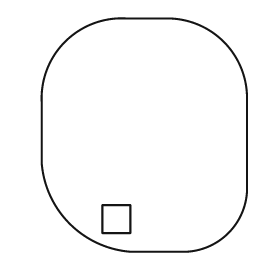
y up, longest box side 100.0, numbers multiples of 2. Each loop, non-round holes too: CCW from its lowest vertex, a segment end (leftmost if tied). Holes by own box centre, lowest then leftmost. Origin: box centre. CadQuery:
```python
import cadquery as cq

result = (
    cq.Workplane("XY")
    .moveTo(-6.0, -50.0)
    .lineTo(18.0, -50.0)
    .threePointArc((36.0, -42.0), (44.0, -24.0))
    .lineTo(44.0, 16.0)
    .threePointArc((34.0, 40.0), (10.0, 50.0))
    .lineTo(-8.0, 50.0)
    .threePointArc((-34.0, 40.0), (-44.0, 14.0))
    .lineTo(-44.0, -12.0)
    .threePointArc((-32.0, -38.0), (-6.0, -50.0))
    .close()
    .moveTo(-18.0, -42.0)
    .lineTo(-6.0, -42.0)
    .lineTo(-6.0, -30.0)
    .lineTo(-18.0, -30.0)
    .close()
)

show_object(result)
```